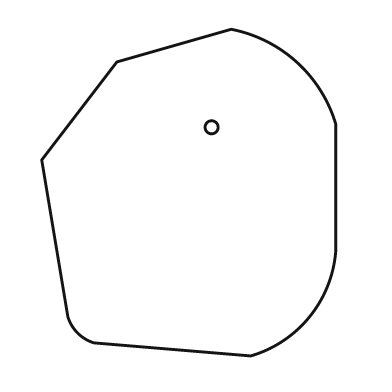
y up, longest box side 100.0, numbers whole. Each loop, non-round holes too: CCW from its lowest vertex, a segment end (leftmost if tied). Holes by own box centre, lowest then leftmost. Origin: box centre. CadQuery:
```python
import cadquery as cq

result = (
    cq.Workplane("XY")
    .moveTo(19.0, -50.0)
    .threePointArc((37.0, -38.0), (45.0, -18.0))
    .lineTo(45.0, 21.0)
    .threePointArc((33.0, 40.0), (13.0, 50.0))
    .lineTo(-22.0, 40.0)
    .lineTo(-45.0, 10.0)
    .lineTo(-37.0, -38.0)
    .threePointArc((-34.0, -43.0), (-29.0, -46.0))
    .close()
    .moveTo(7.0, 20.0)
    .circle(2.0)
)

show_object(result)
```